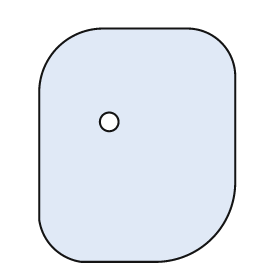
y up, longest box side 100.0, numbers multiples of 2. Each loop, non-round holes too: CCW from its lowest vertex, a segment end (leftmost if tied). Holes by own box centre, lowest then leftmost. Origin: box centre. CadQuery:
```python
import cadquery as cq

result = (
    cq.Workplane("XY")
    .moveTo(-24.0, -50.0)
    .lineTo(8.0, -50.0)
    .threePointArc((32.0, -40.0), (42.0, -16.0))
    .lineTo(42.0, 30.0)
    .threePointArc((36.0, 44.0), (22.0, 50.0))
    .lineTo(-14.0, 50.0)
    .threePointArc((-34.0, 42.0), (-42.0, 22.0))
    .lineTo(-42.0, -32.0)
    .threePointArc((-36.0, -44.0), (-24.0, -50.0))
    .close()
    .moveTo(-12.0, 10.0)
    .circle(4.0)
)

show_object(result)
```